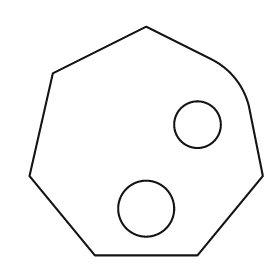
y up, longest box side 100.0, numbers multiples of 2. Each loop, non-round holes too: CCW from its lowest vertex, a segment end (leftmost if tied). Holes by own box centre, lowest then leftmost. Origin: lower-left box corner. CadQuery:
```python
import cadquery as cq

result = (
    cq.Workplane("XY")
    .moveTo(28.0, 0.0)
    .lineTo(72.0, 0.0)
    .lineTo(100.0, 34.0)
    .lineTo(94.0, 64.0)
    .threePointArc((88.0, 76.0), (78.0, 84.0))
    .lineTo(50.0, 98.0)
    .lineTo(10.0, 78.0)
    .lineTo(0.0, 34.0)
    .close()
    .moveTo(50.0, 20.0)
    .circle(12.0)
    .moveTo(72.0, 56.0)
    .circle(10.0)
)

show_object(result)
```